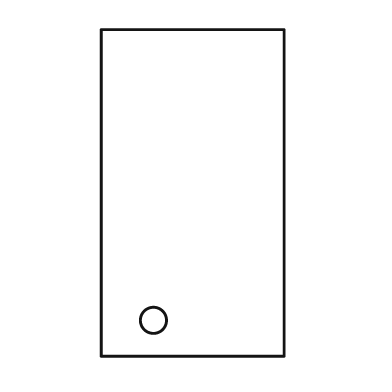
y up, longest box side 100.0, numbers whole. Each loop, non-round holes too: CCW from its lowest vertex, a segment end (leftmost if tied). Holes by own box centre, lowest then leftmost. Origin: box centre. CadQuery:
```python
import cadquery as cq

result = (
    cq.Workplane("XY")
    .moveTo(-28.0, -50.0)
    .lineTo(28.0, -50.0)
    .lineTo(28.0, 50.0)
    .lineTo(-28.0, 50.0)
    .close()
    .moveTo(-12.0, -39.0)
    .circle(4.0)
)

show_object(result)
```